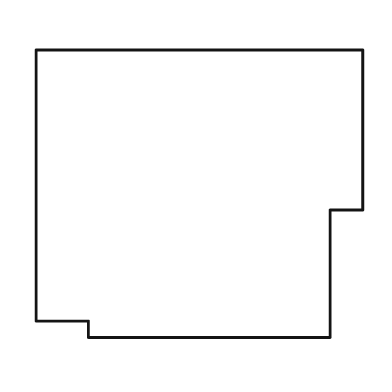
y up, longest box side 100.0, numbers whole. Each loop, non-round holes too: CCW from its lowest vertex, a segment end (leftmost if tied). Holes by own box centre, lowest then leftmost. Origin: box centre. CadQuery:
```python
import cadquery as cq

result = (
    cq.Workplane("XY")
    .moveTo(-34.0, -44.0)
    .lineTo(40.0, -44.0)
    .lineTo(40.0, -5.0)
    .lineTo(50.0, -5.0)
    .lineTo(50.0, 44.0)
    .lineTo(-50.0, 44.0)
    .lineTo(-50.0, -39.0)
    .lineTo(-34.0, -39.0)
    .close()
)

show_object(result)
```